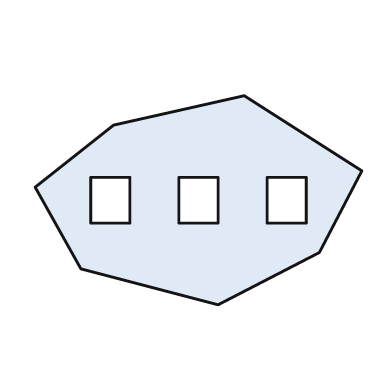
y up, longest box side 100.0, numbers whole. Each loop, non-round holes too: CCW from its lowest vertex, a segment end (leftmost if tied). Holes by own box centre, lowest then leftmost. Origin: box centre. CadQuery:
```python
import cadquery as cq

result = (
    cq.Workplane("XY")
    .moveTo(6.0, -32.0)
    .lineTo(37.0, -16.0)
    .lineTo(50.0, 9.0)
    .lineTo(14.0, 32.0)
    .lineTo(-26.0, 23.0)
    .lineTo(-50.0, 4.0)
    .lineTo(-36.0, -21.0)
    .close()
    .moveTo(-33.0, -7.0)
    .lineTo(-21.0, -7.0)
    .lineTo(-21.0, 7.0)
    .lineTo(-33.0, 7.0)
    .close()
    .moveTo(-6.0, -7.0)
    .lineTo(6.0, -7.0)
    .lineTo(6.0, 7.0)
    .lineTo(-6.0, 7.0)
    .close()
    .moveTo(21.0, -7.0)
    .lineTo(33.0, -7.0)
    .lineTo(33.0, 7.0)
    .lineTo(21.0, 7.0)
    .close()
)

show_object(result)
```